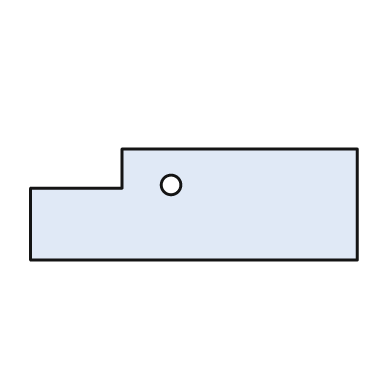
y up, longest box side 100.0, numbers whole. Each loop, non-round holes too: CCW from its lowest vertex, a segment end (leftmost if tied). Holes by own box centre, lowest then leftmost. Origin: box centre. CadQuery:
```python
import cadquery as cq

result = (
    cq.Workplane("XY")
    .moveTo(-50.0, -17.0)
    .lineTo(50.0, -17.0)
    .lineTo(50.0, 17.0)
    .lineTo(-22.0, 17.0)
    .lineTo(-22.0, 5.0)
    .lineTo(-50.0, 5.0)
    .close()
    .moveTo(-7.0, 6.0)
    .circle(3.0)
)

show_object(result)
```